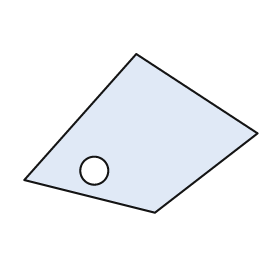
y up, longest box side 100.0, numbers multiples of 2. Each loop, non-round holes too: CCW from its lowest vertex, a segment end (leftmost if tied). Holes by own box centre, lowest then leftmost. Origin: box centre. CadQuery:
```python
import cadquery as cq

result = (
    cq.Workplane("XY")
    .moveTo(6.0, -34.0)
    .lineTo(50.0, 0.0)
    .lineTo(-2.0, 34.0)
    .lineTo(-50.0, -20.0)
    .close()
    .moveTo(-20.0, -16.0)
    .circle(6.0)
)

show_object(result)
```